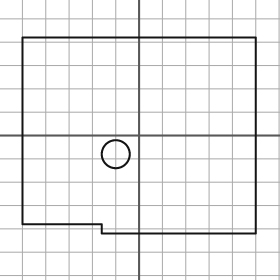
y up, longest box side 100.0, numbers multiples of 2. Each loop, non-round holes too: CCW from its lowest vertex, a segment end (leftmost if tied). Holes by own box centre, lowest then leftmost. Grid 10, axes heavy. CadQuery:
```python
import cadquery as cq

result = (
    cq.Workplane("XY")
    .moveTo(-16.0, -42.0)
    .lineTo(50.0, -42.0)
    .lineTo(50.0, 42.0)
    .lineTo(-50.0, 42.0)
    .lineTo(-50.0, -38.0)
    .lineTo(-16.0, -38.0)
    .close()
    .moveTo(-10.0, -8.0)
    .circle(6.0)
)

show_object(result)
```